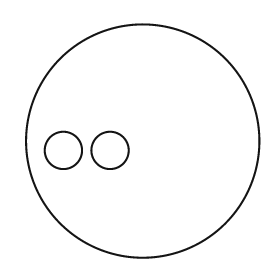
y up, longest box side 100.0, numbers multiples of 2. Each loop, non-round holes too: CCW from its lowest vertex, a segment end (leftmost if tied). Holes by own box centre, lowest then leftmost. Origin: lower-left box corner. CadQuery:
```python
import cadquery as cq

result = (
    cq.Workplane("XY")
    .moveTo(50.0, 50.0)
    .circle(50.0)
    .moveTo(16.0, 46.0)
    .circle(8.0)
    .moveTo(36.0, 46.0)
    .circle(8.0)
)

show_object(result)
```